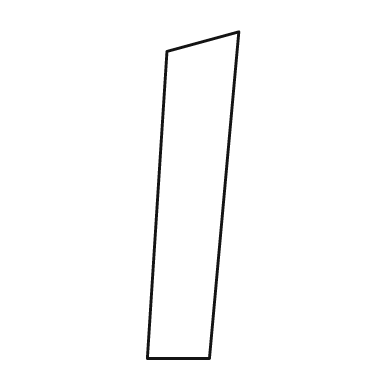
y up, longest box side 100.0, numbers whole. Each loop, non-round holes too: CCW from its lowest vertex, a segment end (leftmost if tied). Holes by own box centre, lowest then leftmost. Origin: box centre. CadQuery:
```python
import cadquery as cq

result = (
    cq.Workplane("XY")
    .moveTo(-14.0, -50.0)
    .lineTo(5.0, -50.0)
    .lineTo(14.0, 50.0)
    .lineTo(-8.0, 44.0)
    .close()
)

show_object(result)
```